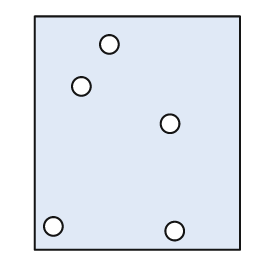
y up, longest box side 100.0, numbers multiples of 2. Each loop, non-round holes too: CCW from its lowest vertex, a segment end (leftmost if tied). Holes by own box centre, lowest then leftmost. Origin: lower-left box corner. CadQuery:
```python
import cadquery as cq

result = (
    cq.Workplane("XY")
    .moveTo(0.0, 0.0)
    .lineTo(88.0, 0.0)
    .lineTo(88.0, 100.0)
    .lineTo(0.0, 100.0)
    .close()
    .moveTo(60.0, 8.0)
    .circle(4.0)
    .moveTo(8.0, 10.0)
    .circle(4.0)
    .moveTo(58.0, 54.0)
    .circle(4.0)
    .moveTo(20.0, 70.0)
    .circle(4.0)
    .moveTo(32.0, 88.0)
    .circle(4.0)
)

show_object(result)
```